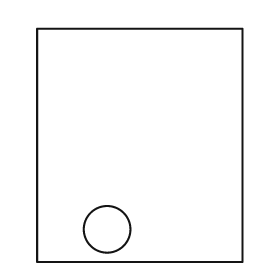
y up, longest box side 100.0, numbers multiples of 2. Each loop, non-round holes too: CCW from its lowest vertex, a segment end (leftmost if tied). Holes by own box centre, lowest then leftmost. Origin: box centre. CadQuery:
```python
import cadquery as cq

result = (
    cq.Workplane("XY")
    .moveTo(-44.0, -50.0)
    .lineTo(44.0, -50.0)
    .lineTo(44.0, 50.0)
    .lineTo(-44.0, 50.0)
    .close()
    .moveTo(-14.0, -36.0)
    .circle(10.0)
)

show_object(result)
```